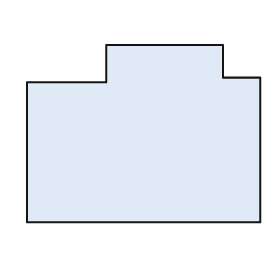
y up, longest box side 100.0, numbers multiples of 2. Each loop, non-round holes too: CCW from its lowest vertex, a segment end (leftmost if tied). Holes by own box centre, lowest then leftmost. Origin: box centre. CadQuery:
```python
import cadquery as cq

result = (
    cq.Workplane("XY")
    .moveTo(-50.0, -38.0)
    .lineTo(50.0, -38.0)
    .lineTo(50.0, 24.0)
    .lineTo(34.0, 24.0)
    .lineTo(34.0, 38.0)
    .lineTo(-16.0, 38.0)
    .lineTo(-16.0, 22.0)
    .lineTo(-50.0, 22.0)
    .close()
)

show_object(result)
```